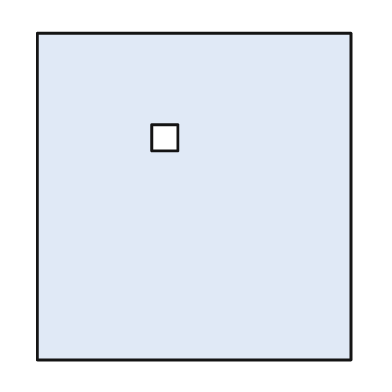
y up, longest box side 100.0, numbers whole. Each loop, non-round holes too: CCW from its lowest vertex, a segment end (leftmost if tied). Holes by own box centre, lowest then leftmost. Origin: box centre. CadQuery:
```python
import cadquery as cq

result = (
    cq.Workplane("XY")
    .moveTo(-48.0, -50.0)
    .lineTo(48.0, -50.0)
    .lineTo(48.0, 50.0)
    .lineTo(-48.0, 50.0)
    .close()
    .moveTo(-13.0, 14.0)
    .lineTo(-5.0, 14.0)
    .lineTo(-5.0, 22.0)
    .lineTo(-13.0, 22.0)
    .close()
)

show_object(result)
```